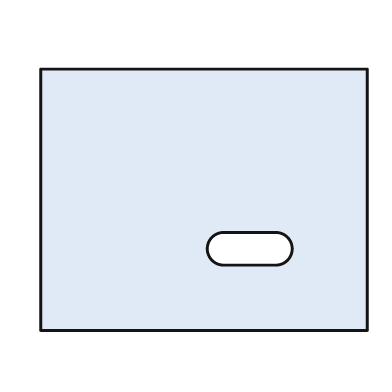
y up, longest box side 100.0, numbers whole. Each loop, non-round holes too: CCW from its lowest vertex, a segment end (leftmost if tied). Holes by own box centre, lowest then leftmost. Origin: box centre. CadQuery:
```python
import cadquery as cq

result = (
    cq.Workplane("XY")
    .moveTo(-50.0, -40.0)
    .lineTo(50.0, -40.0)
    .lineTo(50.0, 40.0)
    .lineTo(-50.0, 40.0)
    .close()
    .moveTo(6.0, -20.0)
    .lineTo(22.0, -20.0)
    .threePointArc((27.0, -15.0), (22.0, -10.0))
    .lineTo(6.0, -10.0)
    .threePointArc((1.0, -15.0), (6.0, -20.0))
    .close()
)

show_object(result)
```